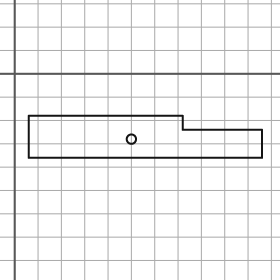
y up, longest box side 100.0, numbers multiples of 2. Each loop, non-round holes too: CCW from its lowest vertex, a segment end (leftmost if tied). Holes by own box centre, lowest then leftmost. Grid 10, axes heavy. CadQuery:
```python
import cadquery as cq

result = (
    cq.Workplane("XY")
    .moveTo(6.0, -36.0)
    .lineTo(106.0, -36.0)
    .lineTo(106.0, -24.0)
    .lineTo(72.0, -24.0)
    .lineTo(72.0, -18.0)
    .lineTo(6.0, -18.0)
    .close()
    .moveTo(50.0, -28.0)
    .circle(2.0)
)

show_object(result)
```